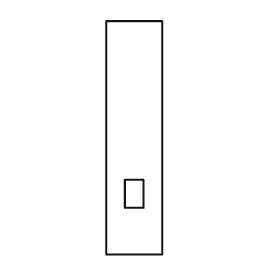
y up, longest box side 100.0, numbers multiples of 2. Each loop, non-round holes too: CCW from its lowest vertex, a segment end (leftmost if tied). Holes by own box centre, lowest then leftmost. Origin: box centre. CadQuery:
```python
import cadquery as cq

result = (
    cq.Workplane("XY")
    .moveTo(-12.0, -50.0)
    .lineTo(12.0, -50.0)
    .lineTo(12.0, 50.0)
    .lineTo(-12.0, 50.0)
    .close()
    .moveTo(-4.0, -30.0)
    .lineTo(4.0, -30.0)
    .lineTo(4.0, -18.0)
    .lineTo(-4.0, -18.0)
    .close()
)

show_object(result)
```